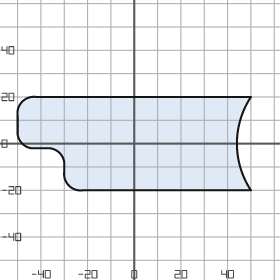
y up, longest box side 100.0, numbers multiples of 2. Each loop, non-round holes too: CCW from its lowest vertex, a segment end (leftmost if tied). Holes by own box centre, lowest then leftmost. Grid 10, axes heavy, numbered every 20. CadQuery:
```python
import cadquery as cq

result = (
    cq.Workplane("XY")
    .moveTo(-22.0, -20.0)
    .lineTo(50.0, -20.0)
    .threePointArc((44.0, 0.0), (50.0, 20.0))
    .lineTo(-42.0, 20.0)
    .threePointArc((-48.0, 18.0), (-50.0, 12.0))
    .lineTo(-50.0, 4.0)
    .threePointArc((-48.0, 0.0), (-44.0, -2.0))
    .lineTo(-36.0, -2.0)
    .threePointArc((-32.0, -4.0), (-30.0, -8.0))
    .lineTo(-30.0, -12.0)
    .threePointArc((-28.0, -18.0), (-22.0, -20.0))
    .close()
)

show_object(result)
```